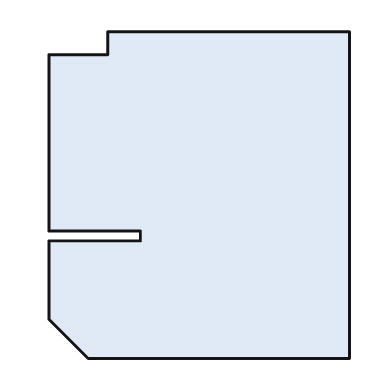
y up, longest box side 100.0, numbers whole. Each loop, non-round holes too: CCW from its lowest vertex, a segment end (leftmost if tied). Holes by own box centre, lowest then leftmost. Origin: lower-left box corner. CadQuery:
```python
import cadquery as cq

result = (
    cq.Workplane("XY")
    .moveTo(12.0, 0.0)
    .lineTo(92.0, 0.0)
    .lineTo(92.0, 100.0)
    .lineTo(18.0, 100.0)
    .lineTo(18.0, 93.0)
    .lineTo(0.0, 93.0)
    .lineTo(0.0, 39.0)
    .lineTo(28.0, 39.0)
    .lineTo(28.0, 36.0)
    .lineTo(0.0, 36.0)
    .lineTo(0.0, 12.0)
    .close()
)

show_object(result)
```